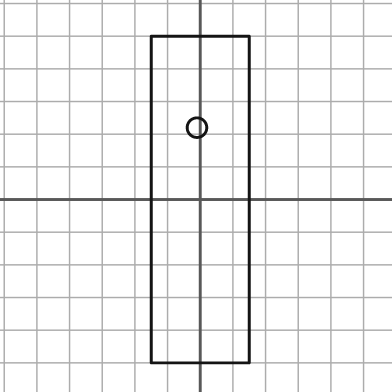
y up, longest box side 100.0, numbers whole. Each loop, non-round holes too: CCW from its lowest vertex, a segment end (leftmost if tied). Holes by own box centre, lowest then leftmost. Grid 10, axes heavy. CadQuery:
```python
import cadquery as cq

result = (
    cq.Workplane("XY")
    .moveTo(-15.0, -50.0)
    .lineTo(15.0, -50.0)
    .lineTo(15.0, 50.0)
    .lineTo(-15.0, 50.0)
    .close()
    .moveTo(-1.0, 22.0)
    .circle(3.0)
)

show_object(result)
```